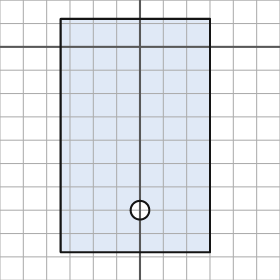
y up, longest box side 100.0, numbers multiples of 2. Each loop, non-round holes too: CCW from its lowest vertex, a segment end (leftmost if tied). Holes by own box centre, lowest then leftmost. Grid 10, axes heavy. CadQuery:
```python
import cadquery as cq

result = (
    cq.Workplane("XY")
    .moveTo(-34.0, -88.0)
    .lineTo(30.0, -88.0)
    .lineTo(30.0, 12.0)
    .lineTo(-34.0, 12.0)
    .close()
    .moveTo(0.0, -70.0)
    .circle(4.0)
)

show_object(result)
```